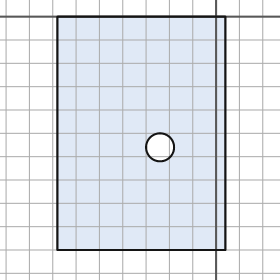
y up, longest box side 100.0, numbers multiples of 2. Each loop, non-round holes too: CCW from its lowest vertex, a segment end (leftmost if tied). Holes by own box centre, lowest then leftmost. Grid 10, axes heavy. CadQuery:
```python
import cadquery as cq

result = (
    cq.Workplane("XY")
    .moveTo(-68.0, -100.0)
    .lineTo(4.0, -100.0)
    .lineTo(4.0, 0.0)
    .lineTo(-68.0, 0.0)
    .close()
    .moveTo(-24.0, -56.0)
    .circle(6.0)
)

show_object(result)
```